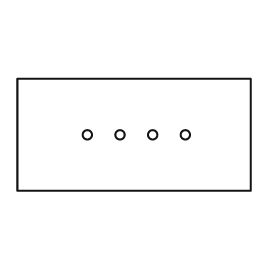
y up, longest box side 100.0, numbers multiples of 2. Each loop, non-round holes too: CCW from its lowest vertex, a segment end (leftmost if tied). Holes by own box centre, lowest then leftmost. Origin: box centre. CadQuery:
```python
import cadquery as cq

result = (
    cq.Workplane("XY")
    .moveTo(-50.0, -24.0)
    .lineTo(50.0, -24.0)
    .lineTo(50.0, 24.0)
    .lineTo(-50.0, 24.0)
    .close()
    .moveTo(-20.0, 0.0)
    .circle(2.0)
    .moveTo(-6.0, 0.0)
    .circle(2.0)
    .moveTo(8.0, 0.0)
    .circle(2.0)
    .moveTo(22.0, 0.0)
    .circle(2.0)
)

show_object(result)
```